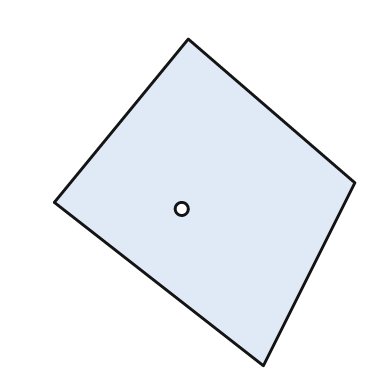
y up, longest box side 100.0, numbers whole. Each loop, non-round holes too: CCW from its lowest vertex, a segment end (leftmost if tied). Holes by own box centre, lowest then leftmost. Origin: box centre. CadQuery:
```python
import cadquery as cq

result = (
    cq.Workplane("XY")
    .moveTo(18.0, -50.0)
    .lineTo(46.0, 6.0)
    .lineTo(-5.0, 50.0)
    .lineTo(-46.0, 0.0)
    .close()
    .moveTo(-7.0, -2.0)
    .circle(2.0)
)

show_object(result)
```